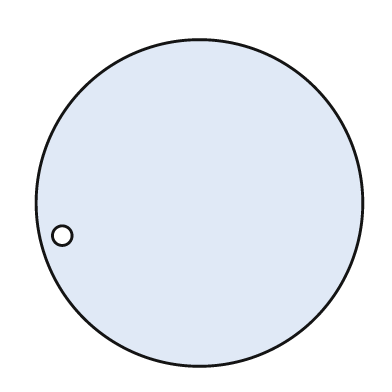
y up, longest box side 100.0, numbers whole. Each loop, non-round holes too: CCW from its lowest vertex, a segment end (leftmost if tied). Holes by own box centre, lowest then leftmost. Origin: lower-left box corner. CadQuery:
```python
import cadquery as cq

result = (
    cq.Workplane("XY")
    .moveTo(50.0, 50.0)
    .circle(50.0)
    .moveTo(8.0, 40.0)
    .circle(3.0)
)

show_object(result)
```